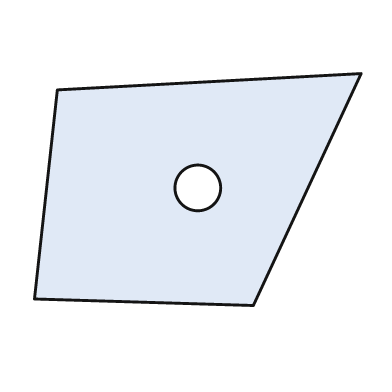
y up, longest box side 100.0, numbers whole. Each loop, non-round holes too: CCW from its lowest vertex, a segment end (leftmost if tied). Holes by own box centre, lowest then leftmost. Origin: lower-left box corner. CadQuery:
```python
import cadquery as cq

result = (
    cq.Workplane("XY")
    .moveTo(67.0, 0.0)
    .lineTo(100.0, 71.0)
    .lineTo(7.0, 66.0)
    .lineTo(0.0, 2.0)
    .close()
    .moveTo(50.0, 36.0)
    .circle(7.0)
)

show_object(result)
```